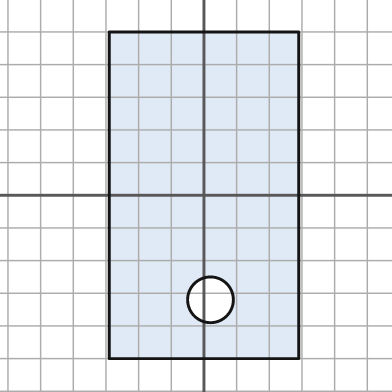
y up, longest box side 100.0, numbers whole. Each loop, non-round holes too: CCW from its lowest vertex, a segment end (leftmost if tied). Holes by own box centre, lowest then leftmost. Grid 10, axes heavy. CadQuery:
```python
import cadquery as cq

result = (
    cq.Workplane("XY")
    .moveTo(-29.0, -50.0)
    .lineTo(29.0, -50.0)
    .lineTo(29.0, 50.0)
    .lineTo(-29.0, 50.0)
    .close()
    .moveTo(2.0, -32.0)
    .circle(7.0)
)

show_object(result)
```